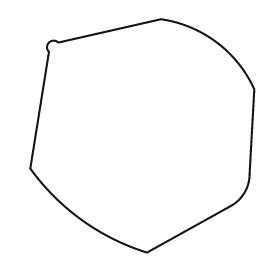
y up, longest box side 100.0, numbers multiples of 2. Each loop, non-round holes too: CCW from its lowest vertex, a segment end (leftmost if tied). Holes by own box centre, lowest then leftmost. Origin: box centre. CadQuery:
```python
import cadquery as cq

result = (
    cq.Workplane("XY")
    .moveTo(2.0, -50.0)
    .lineTo(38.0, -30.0)
    .threePointArc((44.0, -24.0), (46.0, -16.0))
    .lineTo(48.0, 20.0)
    .threePointArc((32.0, 40.0), (8.0, 50.0))
    .lineTo(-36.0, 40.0)
    .threePointArc((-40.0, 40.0), (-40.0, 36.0))
    .lineTo(-48.0, -14.0)
    .threePointArc((-26.0, -36.0), (2.0, -50.0))
    .close()
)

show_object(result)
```